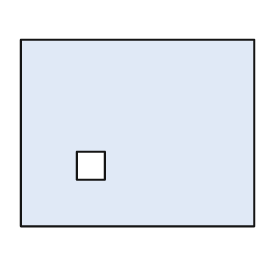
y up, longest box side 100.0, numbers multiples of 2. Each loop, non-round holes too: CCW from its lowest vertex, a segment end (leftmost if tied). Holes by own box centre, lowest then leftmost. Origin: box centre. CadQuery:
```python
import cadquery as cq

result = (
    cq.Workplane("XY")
    .moveTo(-50.0, -40.0)
    .lineTo(50.0, -40.0)
    .lineTo(50.0, 40.0)
    .lineTo(-50.0, 40.0)
    .close()
    .moveTo(-26.0, -20.0)
    .lineTo(-14.0, -20.0)
    .lineTo(-14.0, -8.0)
    .lineTo(-26.0, -8.0)
    .close()
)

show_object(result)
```